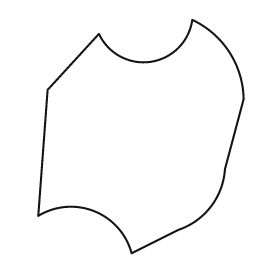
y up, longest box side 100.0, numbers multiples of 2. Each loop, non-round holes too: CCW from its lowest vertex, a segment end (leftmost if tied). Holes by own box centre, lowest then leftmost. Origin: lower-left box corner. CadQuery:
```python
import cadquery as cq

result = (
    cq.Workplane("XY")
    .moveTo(40.0, 0.0)
    .lineTo(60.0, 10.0)
    .threePointArc((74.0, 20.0), (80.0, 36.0))
    .lineTo(88.0, 66.0)
    .threePointArc((82.0, 86.0), (66.0, 100.0))
    .threePointArc((48.0, 82.0), (26.0, 94.0))
    .lineTo(4.0, 70.0)
    .lineTo(0.0, 16.0)
    .threePointArc((24.0, 18.0), (40.0, 0.0))
    .close()
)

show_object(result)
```